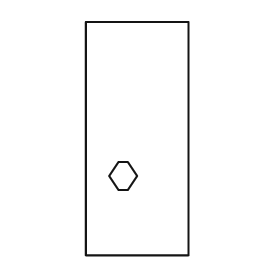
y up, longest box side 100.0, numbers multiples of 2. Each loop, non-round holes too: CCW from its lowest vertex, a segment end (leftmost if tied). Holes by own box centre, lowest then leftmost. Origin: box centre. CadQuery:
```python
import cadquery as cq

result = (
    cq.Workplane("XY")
    .moveTo(-22.0, -50.0)
    .lineTo(22.0, -50.0)
    .lineTo(22.0, 50.0)
    .lineTo(-22.0, 50.0)
    .close()
    .moveTo(-8.0, -22.0)
    .lineTo(-4.0, -22.0)
    .lineTo(0.0, -16.0)
    .lineTo(-4.0, -10.0)
    .lineTo(-8.0, -10.0)
    .lineTo(-12.0, -16.0)
    .close()
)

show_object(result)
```